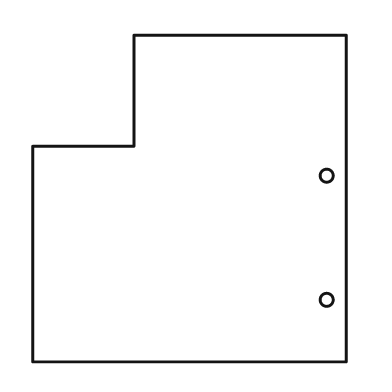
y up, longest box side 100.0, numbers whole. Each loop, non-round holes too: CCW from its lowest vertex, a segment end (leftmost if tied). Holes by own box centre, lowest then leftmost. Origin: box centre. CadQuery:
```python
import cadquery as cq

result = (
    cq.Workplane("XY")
    .moveTo(-48.0, -50.0)
    .lineTo(48.0, -50.0)
    .lineTo(48.0, 50.0)
    .lineTo(-17.0, 50.0)
    .lineTo(-17.0, 16.0)
    .lineTo(-48.0, 16.0)
    .close()
    .moveTo(42.0, -31.0)
    .circle(2.0)
    .moveTo(42.0, 7.0)
    .circle(2.0)
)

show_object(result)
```